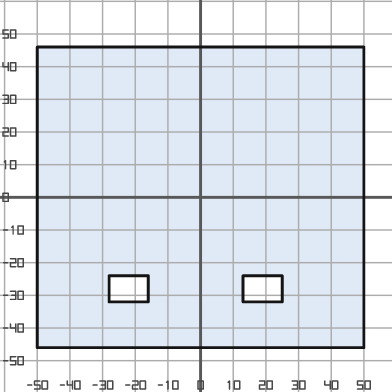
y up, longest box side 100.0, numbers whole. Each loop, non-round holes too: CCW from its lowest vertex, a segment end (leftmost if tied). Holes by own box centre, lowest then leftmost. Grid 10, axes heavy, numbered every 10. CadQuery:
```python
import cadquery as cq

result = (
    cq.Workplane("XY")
    .moveTo(-50.0, -46.0)
    .lineTo(50.0, -46.0)
    .lineTo(50.0, 46.0)
    .lineTo(-50.0, 46.0)
    .close()
    .moveTo(-28.0, -32.0)
    .lineTo(-16.0, -32.0)
    .lineTo(-16.0, -24.0)
    .lineTo(-28.0, -24.0)
    .close()
    .moveTo(13.0, -32.0)
    .lineTo(25.0, -32.0)
    .lineTo(25.0, -24.0)
    .lineTo(13.0, -24.0)
    .close()
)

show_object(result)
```